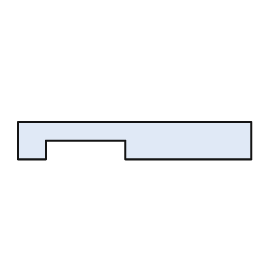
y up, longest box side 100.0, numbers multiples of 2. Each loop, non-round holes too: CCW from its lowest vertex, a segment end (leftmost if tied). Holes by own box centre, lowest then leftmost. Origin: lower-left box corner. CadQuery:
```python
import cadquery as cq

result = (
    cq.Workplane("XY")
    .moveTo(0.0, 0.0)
    .lineTo(12.0, 0.0)
    .lineTo(12.0, 8.0)
    .lineTo(46.0, 8.0)
    .lineTo(46.0, 0.0)
    .lineTo(100.0, 0.0)
    .lineTo(100.0, 16.0)
    .lineTo(0.0, 16.0)
    .close()
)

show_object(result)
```